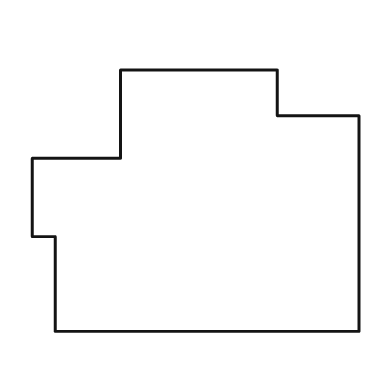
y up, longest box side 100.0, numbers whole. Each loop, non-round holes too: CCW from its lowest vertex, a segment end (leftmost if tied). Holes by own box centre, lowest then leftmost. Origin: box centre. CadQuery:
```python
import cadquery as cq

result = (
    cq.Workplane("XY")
    .moveTo(-43.0, -40.0)
    .lineTo(50.0, -40.0)
    .lineTo(50.0, 26.0)
    .lineTo(25.0, 26.0)
    .lineTo(25.0, 40.0)
    .lineTo(-23.0, 40.0)
    .lineTo(-23.0, 13.0)
    .lineTo(-50.0, 13.0)
    .lineTo(-50.0, -11.0)
    .lineTo(-43.0, -11.0)
    .close()
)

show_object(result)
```